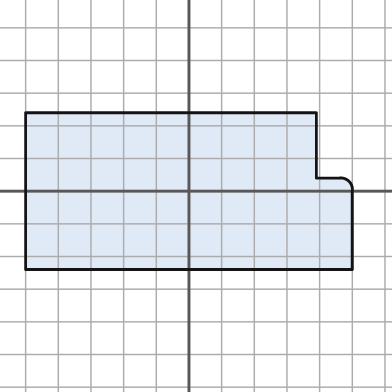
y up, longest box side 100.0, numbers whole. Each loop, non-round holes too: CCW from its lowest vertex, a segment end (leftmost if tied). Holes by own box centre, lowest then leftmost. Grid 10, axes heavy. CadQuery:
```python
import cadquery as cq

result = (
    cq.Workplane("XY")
    .moveTo(-50.0, -24.0)
    .lineTo(50.0, -24.0)
    .lineTo(50.0, 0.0)
    .threePointArc((49.0, 3.0), (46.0, 4.0))
    .lineTo(39.0, 4.0)
    .lineTo(39.0, 24.0)
    .lineTo(-50.0, 24.0)
    .close()
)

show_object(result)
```